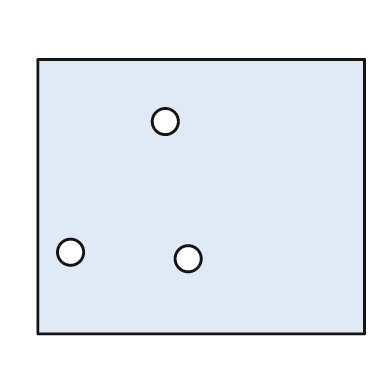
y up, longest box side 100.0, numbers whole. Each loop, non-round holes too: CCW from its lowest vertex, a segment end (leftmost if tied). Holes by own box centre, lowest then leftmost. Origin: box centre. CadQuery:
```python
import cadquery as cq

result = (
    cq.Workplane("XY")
    .moveTo(-50.0, -42.0)
    .lineTo(50.0, -42.0)
    .lineTo(50.0, 42.0)
    .lineTo(-50.0, 42.0)
    .close()
    .moveTo(-4.0, -19.0)
    .circle(4.0)
    .moveTo(-40.0, -17.0)
    .circle(4.0)
    .moveTo(-11.0, 23.0)
    .circle(4.0)
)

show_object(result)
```